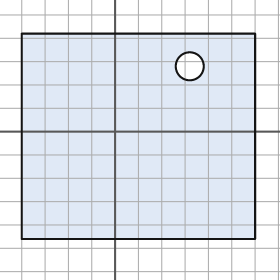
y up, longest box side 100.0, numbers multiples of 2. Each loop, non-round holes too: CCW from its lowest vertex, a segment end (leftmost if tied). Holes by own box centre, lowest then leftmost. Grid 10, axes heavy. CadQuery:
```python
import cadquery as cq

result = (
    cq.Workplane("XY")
    .moveTo(-40.0, -46.0)
    .lineTo(60.0, -46.0)
    .lineTo(60.0, 42.0)
    .lineTo(-40.0, 42.0)
    .close()
    .moveTo(32.0, 28.0)
    .circle(6.0)
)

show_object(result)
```